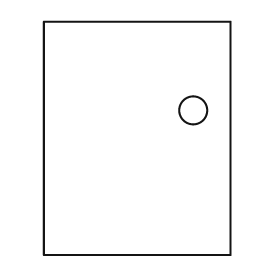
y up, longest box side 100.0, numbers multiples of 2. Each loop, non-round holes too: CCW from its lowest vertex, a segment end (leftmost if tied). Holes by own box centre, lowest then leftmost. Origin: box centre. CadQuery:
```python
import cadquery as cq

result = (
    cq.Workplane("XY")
    .moveTo(-40.0, -50.0)
    .lineTo(40.0, -50.0)
    .lineTo(40.0, 50.0)
    .lineTo(-40.0, 50.0)
    .close()
    .moveTo(24.0, 12.0)
    .circle(6.0)
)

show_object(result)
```